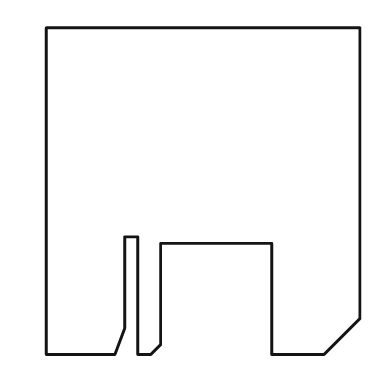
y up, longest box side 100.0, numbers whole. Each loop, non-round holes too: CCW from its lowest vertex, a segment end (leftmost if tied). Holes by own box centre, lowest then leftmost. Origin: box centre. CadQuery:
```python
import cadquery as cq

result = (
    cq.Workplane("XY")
    .moveTo(-48.0, -50.0)
    .lineTo(-27.0, -50.0)
    .lineTo(-24.0, -42.0)
    .lineTo(-24.0, -14.0)
    .lineTo(-20.0, -14.0)
    .lineTo(-20.0, -50.0)
    .lineTo(-16.0, -50.0)
    .lineTo(-13.0, -47.0)
    .lineTo(-13.0, -16.0)
    .lineTo(21.0, -16.0)
    .lineTo(21.0, -50.0)
    .lineTo(37.0, -50.0)
    .lineTo(48.0, -39.0)
    .lineTo(48.0, 50.0)
    .lineTo(-48.0, 50.0)
    .close()
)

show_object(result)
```